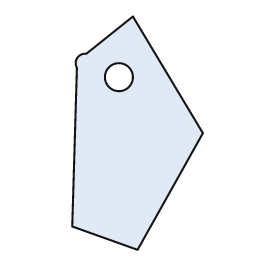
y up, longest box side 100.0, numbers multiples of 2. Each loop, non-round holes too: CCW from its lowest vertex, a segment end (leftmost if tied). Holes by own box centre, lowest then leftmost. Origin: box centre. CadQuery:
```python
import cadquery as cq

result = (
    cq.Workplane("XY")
    .moveTo(0.0, -50.0)
    .lineTo(28.0, 0.0)
    .lineTo(-2.0, 50.0)
    .lineTo(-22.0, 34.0)
    .threePointArc((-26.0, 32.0), (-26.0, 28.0))
    .lineTo(-28.0, -40.0)
    .close()
    .moveTo(-8.0, 24.0)
    .circle(6.0)
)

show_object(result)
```